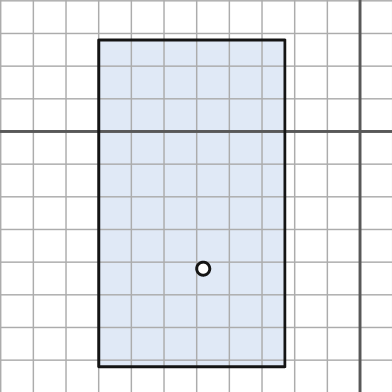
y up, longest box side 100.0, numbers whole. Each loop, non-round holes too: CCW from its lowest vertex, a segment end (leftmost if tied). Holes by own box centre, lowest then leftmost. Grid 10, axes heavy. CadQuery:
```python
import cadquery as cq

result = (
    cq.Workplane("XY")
    .moveTo(-80.0, -72.0)
    .lineTo(-23.0, -72.0)
    .lineTo(-23.0, 28.0)
    .lineTo(-80.0, 28.0)
    .close()
    .moveTo(-48.0, -42.0)
    .circle(2.0)
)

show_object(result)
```